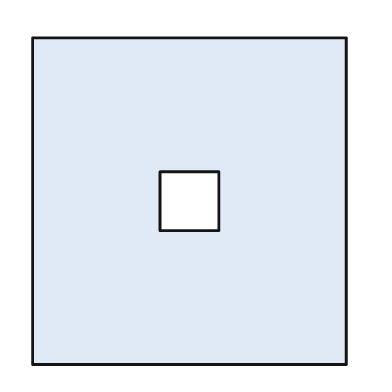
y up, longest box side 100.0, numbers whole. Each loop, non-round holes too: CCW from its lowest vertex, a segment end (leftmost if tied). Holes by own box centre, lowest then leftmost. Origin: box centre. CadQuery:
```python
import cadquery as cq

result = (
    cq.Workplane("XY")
    .moveTo(-48.0, -50.0)
    .lineTo(48.0, -50.0)
    .lineTo(48.0, 50.0)
    .lineTo(-48.0, 50.0)
    .close()
    .moveTo(-9.0, -9.0)
    .lineTo(9.0, -9.0)
    .lineTo(9.0, 9.0)
    .lineTo(-9.0, 9.0)
    .close()
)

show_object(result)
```